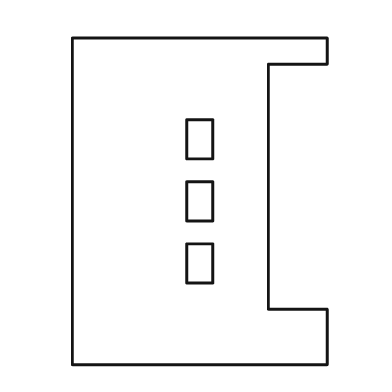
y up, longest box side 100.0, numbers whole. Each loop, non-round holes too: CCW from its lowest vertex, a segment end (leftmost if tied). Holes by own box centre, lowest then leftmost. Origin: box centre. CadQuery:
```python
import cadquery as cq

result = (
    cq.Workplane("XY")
    .moveTo(-39.0, -50.0)
    .lineTo(39.0, -50.0)
    .lineTo(39.0, -33.0)
    .lineTo(21.0, -33.0)
    .lineTo(21.0, 42.0)
    .lineTo(39.0, 42.0)
    .lineTo(39.0, 50.0)
    .lineTo(-39.0, 50.0)
    .close()
    .moveTo(-4.0, -25.0)
    .lineTo(4.0, -25.0)
    .lineTo(4.0, -13.0)
    .lineTo(-4.0, -13.0)
    .close()
    .moveTo(-4.0, -6.0)
    .lineTo(4.0, -6.0)
    .lineTo(4.0, 6.0)
    .lineTo(-4.0, 6.0)
    .close()
    .moveTo(-4.0, 13.0)
    .lineTo(4.0, 13.0)
    .lineTo(4.0, 25.0)
    .lineTo(-4.0, 25.0)
    .close()
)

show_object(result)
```